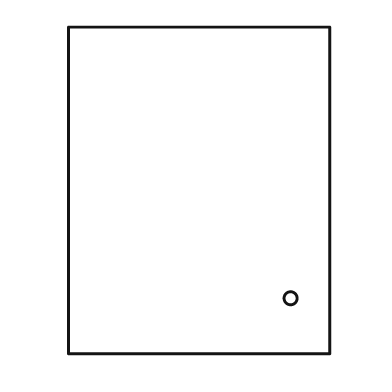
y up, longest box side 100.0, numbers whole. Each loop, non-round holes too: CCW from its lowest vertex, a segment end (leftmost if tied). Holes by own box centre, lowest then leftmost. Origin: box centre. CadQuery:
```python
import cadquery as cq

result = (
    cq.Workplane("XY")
    .moveTo(-40.0, -50.0)
    .lineTo(40.0, -50.0)
    .lineTo(40.0, 50.0)
    .lineTo(-40.0, 50.0)
    .close()
    .moveTo(28.0, -33.0)
    .circle(2.0)
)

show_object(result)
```